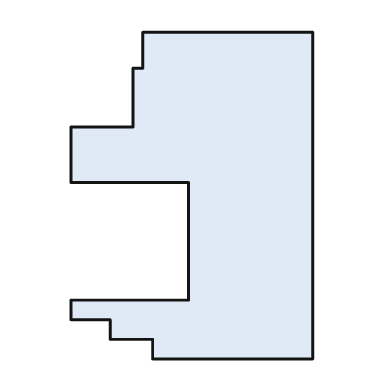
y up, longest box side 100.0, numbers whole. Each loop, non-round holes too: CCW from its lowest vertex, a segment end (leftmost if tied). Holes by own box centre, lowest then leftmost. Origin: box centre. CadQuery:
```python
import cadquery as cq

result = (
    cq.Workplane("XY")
    .moveTo(-12.0, -50.0)
    .lineTo(37.0, -50.0)
    .lineTo(37.0, 50.0)
    .lineTo(-15.0, 50.0)
    .lineTo(-15.0, 39.0)
    .lineTo(-18.0, 39.0)
    .lineTo(-18.0, 21.0)
    .lineTo(-37.0, 21.0)
    .lineTo(-37.0, 4.0)
    .lineTo(-1.0, 4.0)
    .lineTo(-1.0, -32.0)
    .lineTo(-37.0, -32.0)
    .lineTo(-37.0, -38.0)
    .lineTo(-25.0, -38.0)
    .lineTo(-25.0, -44.0)
    .lineTo(-12.0, -44.0)
    .close()
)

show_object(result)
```